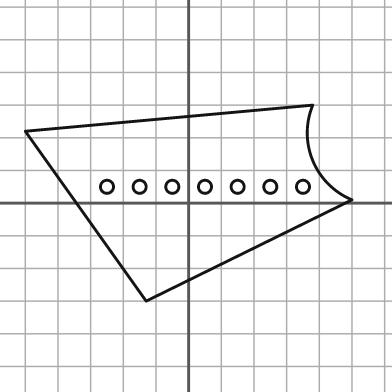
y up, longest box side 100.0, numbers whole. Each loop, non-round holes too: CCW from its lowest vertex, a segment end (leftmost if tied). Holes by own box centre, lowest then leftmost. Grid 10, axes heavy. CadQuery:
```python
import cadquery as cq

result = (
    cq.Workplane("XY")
    .moveTo(-13.0, -30.0)
    .lineTo(50.0, 1.0)
    .threePointArc((38.0, 13.0), (38.0, 30.0))
    .lineTo(-50.0, 22.0)
    .close()
    .moveTo(-25.0, 5.0)
    .circle(2.0)
    .moveTo(-15.0, 5.0)
    .circle(2.0)
    .moveTo(-5.0, 5.0)
    .circle(2.0)
    .moveTo(5.0, 5.0)
    .circle(2.0)
    .moveTo(15.0, 5.0)
    .circle(2.0)
    .moveTo(25.0, 5.0)
    .circle(2.0)
    .moveTo(35.0, 5.0)
    .circle(2.0)
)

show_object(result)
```